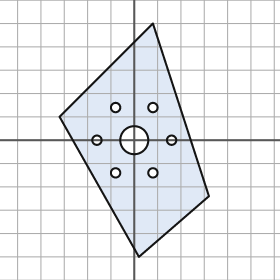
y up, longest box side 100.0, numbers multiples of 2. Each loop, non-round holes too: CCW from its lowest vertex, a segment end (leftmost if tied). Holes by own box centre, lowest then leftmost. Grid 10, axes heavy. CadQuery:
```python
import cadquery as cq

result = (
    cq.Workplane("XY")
    .moveTo(2.0, -50.0)
    .lineTo(32.0, -24.0)
    .lineTo(8.0, 50.0)
    .lineTo(-32.0, 10.0)
    .close()
    .moveTo(-8.0, -14.0)
    .circle(2.0)
    .moveTo(8.0, -14.0)
    .circle(2.0)
    .moveTo(-16.0, 0.0)
    .circle(2.0)
    .moveTo(0.0, 0.0)
    .circle(6.0)
    .moveTo(16.0, 0.0)
    .circle(2.0)
    .moveTo(-8.0, 14.0)
    .circle(2.0)
    .moveTo(8.0, 14.0)
    .circle(2.0)
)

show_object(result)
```